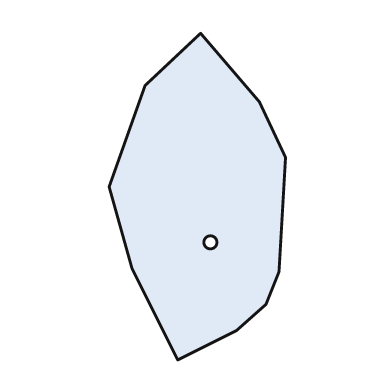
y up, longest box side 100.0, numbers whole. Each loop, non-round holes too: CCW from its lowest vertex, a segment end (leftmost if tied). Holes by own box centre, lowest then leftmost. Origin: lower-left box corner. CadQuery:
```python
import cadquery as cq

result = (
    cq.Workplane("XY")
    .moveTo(21.0, 0.0)
    .lineTo(39.0, 9.0)
    .lineTo(48.0, 17.0)
    .lineTo(52.0, 27.0)
    .lineTo(54.0, 62.0)
    .lineTo(46.0, 79.0)
    .lineTo(28.0, 100.0)
    .lineTo(11.0, 84.0)
    .lineTo(0.0, 53.0)
    .lineTo(7.0, 28.0)
    .close()
    .moveTo(31.0, 36.0)
    .circle(2.0)
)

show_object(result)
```